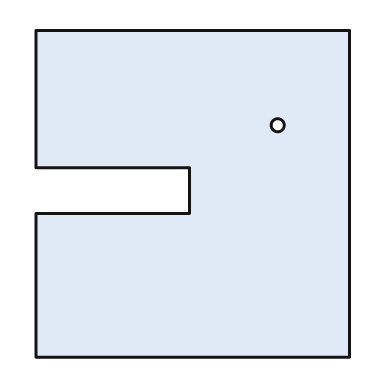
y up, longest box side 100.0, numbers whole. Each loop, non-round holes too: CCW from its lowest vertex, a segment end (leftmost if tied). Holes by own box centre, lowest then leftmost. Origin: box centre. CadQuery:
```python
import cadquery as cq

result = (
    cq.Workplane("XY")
    .moveTo(-48.0, -50.0)
    .lineTo(48.0, -50.0)
    .lineTo(48.0, 50.0)
    .lineTo(-48.0, 50.0)
    .lineTo(-48.0, 8.0)
    .lineTo(-1.0, 8.0)
    .lineTo(-1.0, -6.0)
    .lineTo(-48.0, -6.0)
    .close()
    .moveTo(26.0, 21.0)
    .circle(2.0)
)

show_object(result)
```